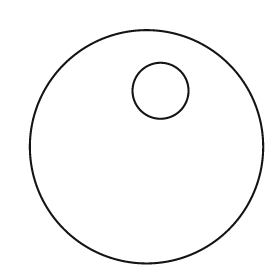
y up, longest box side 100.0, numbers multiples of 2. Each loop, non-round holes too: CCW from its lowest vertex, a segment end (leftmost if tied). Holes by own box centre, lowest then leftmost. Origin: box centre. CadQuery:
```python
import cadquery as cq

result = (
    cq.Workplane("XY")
    .moveTo(0.0, 0.0)
    .circle(50.0)
    .moveTo(6.0, 24.0)
    .circle(12.0)
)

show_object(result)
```